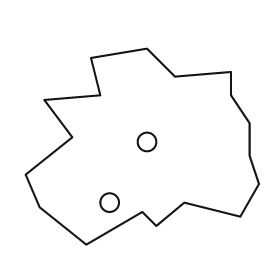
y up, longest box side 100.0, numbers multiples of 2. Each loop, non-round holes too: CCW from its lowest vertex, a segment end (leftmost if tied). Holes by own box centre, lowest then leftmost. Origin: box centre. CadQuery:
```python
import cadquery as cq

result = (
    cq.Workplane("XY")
    .moveTo(-24.0, -42.0)
    .lineTo(0.0, -28.0)
    .lineTo(6.0, -34.0)
    .lineTo(18.0, -24.0)
    .lineTo(42.0, -30.0)
    .lineTo(50.0, -16.0)
    .lineTo(46.0, -4.0)
    .lineTo(46.0, 10.0)
    .lineTo(38.0, 22.0)
    .lineTo(38.0, 32.0)
    .lineTo(14.0, 30.0)
    .lineTo(2.0, 42.0)
    .lineTo(-22.0, 38.0)
    .lineTo(-18.0, 22.0)
    .lineTo(-42.0, 20.0)
    .lineTo(-30.0, 4.0)
    .lineTo(-50.0, -12.0)
    .lineTo(-44.0, -26.0)
    .close()
    .moveTo(-14.0, -24.0)
    .circle(4.0)
    .moveTo(2.0, 2.0)
    .circle(4.0)
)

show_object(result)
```